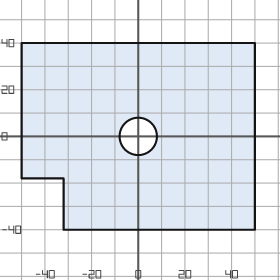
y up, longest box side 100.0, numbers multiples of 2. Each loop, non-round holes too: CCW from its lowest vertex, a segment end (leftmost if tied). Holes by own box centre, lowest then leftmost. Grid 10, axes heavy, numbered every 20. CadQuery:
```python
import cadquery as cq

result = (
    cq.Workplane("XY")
    .moveTo(-32.0, -40.0)
    .lineTo(50.0, -40.0)
    .lineTo(50.0, 40.0)
    .lineTo(-50.0, 40.0)
    .lineTo(-50.0, -18.0)
    .lineTo(-32.0, -18.0)
    .close()
    .moveTo(0.0, 0.0)
    .circle(8.0)
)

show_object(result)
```